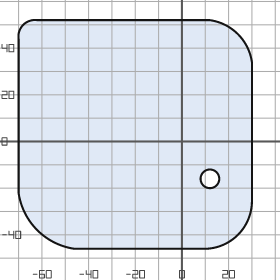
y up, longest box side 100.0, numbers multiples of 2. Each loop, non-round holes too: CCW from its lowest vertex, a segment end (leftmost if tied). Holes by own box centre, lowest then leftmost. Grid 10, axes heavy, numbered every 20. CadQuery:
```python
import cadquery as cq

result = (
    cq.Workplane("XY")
    .moveTo(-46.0, -46.0)
    .lineTo(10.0, -46.0)
    .threePointArc((24.0, -40.0), (30.0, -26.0))
    .lineTo(30.0, 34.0)
    .threePointArc((24.0, 46.0), (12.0, 52.0))
    .lineTo(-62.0, 52.0)
    .threePointArc((-68.0, 50.0), (-70.0, 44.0))
    .lineTo(-70.0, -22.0)
    .threePointArc((-62.0, -38.0), (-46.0, -46.0))
    .close()
    .moveTo(12.0, -16.0)
    .circle(4.0)
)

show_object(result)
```